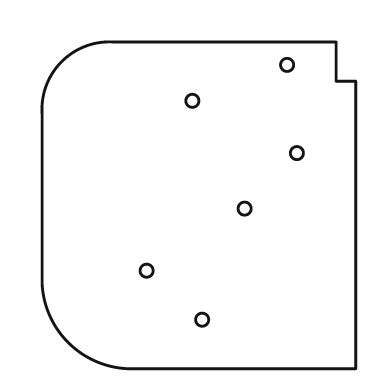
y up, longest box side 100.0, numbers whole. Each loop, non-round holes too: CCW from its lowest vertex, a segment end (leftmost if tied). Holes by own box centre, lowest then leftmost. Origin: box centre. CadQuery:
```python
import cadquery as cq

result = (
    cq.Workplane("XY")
    .moveTo(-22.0, -50.0)
    .lineTo(48.0, -50.0)
    .lineTo(48.0, 38.0)
    .lineTo(42.0, 38.0)
    .lineTo(42.0, 50.0)
    .lineTo(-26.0, 50.0)
    .threePointArc((-42.0, 44.0), (-48.0, 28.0))
    .lineTo(-48.0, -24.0)
    .threePointArc((-40.0, -42.0), (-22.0, -50.0))
    .close()
    .moveTo(1.0, -35.0)
    .circle(2.0)
    .moveTo(-16.0, -20.0)
    .circle(2.0)
    .moveTo(14.0, -1.0)
    .circle(2.0)
    .moveTo(30.0, 16.0)
    .circle(2.0)
    .moveTo(-2.0, 32.0)
    .circle(2.0)
    .moveTo(27.0, 43.0)
    .circle(2.0)
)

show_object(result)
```